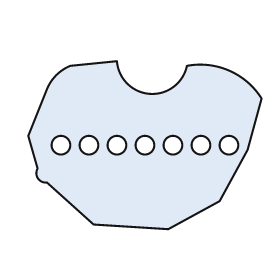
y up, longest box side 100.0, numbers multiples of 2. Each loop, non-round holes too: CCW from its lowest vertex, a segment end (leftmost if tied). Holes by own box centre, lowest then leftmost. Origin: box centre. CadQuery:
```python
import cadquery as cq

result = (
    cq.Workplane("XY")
    .moveTo(10.0, -36.0)
    .lineTo(32.0, -24.0)
    .lineTo(44.0, -2.0)
    .lineTo(50.0, 20.0)
    .threePointArc((36.0, 32.0), (18.0, 34.0))
    .threePointArc((2.0, 22.0), (-12.0, 36.0))
    .lineTo(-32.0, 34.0)
    .threePointArc((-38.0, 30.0), (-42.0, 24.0))
    .lineTo(-50.0, 4.0)
    .lineTo(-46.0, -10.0)
    .threePointArc((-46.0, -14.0), (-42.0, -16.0))
    .lineTo(-22.0, -34.0)
    .close()
    .moveTo(-36.0, 0.0)
    .circle(4.0)
    .moveTo(-24.0, 0.0)
    .circle(4.0)
    .moveTo(-12.0, 0.0)
    .circle(4.0)
    .moveTo(0.0, 0.0)
    .circle(4.0)
    .moveTo(12.0, 0.0)
    .circle(4.0)
    .moveTo(24.0, 0.0)
    .circle(4.0)
    .moveTo(36.0, 0.0)
    .circle(4.0)
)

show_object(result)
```